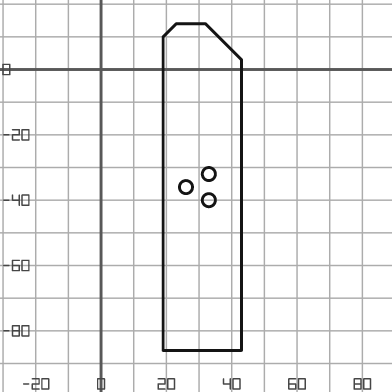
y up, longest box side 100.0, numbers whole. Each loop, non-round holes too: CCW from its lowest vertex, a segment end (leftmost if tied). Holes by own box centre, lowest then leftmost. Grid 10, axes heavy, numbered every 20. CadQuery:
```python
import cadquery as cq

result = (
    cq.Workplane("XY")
    .moveTo(19.0, -86.0)
    .lineTo(43.0, -86.0)
    .lineTo(43.0, 3.0)
    .lineTo(32.0, 14.0)
    .lineTo(23.0, 14.0)
    .lineTo(19.0, 10.0)
    .close()
    .moveTo(33.0, -40.0)
    .circle(2.0)
    .moveTo(26.0, -36.0)
    .circle(2.0)
    .moveTo(33.0, -32.0)
    .circle(2.0)
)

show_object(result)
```